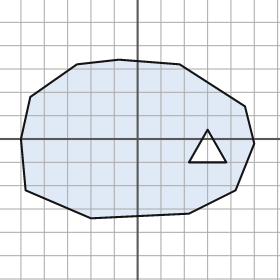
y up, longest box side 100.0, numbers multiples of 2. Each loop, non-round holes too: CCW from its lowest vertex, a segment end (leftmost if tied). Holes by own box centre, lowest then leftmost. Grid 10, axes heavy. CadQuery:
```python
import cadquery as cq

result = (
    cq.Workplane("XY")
    .moveTo(-20.0, -34.0)
    .lineTo(22.0, -32.0)
    .lineTo(42.0, -22.0)
    .lineTo(50.0, -2.0)
    .lineTo(46.0, 14.0)
    .lineTo(18.0, 32.0)
    .lineTo(-8.0, 34.0)
    .lineTo(-26.0, 32.0)
    .lineTo(-46.0, 18.0)
    .lineTo(-50.0, 0.0)
    .lineTo(-48.0, -22.0)
    .close()
    .moveTo(22.0, -10.0)
    .lineTo(38.0, -10.0)
    .lineTo(30.0, 4.0)
    .close()
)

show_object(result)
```